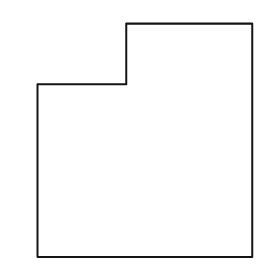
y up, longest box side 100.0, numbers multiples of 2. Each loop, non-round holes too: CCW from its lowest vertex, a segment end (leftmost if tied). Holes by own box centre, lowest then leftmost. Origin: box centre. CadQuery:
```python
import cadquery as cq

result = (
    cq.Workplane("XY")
    .moveTo(-46.0, -50.0)
    .lineTo(46.0, -50.0)
    .lineTo(46.0, 50.0)
    .lineTo(-8.0, 50.0)
    .lineTo(-8.0, 24.0)
    .lineTo(-46.0, 24.0)
    .close()
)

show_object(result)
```